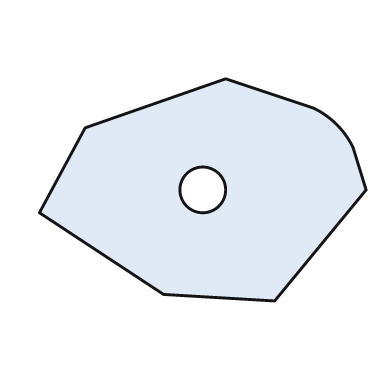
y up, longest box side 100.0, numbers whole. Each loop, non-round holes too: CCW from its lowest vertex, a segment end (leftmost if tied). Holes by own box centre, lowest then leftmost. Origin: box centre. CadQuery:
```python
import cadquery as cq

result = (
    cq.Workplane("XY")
    .moveTo(22.0, -34.0)
    .lineTo(50.0, 0.0)
    .lineTo(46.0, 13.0)
    .threePointArc((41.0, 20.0), (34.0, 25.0))
    .lineTo(7.0, 34.0)
    .lineTo(-36.0, 19.0)
    .lineTo(-50.0, -7.0)
    .lineTo(-12.0, -32.0)
    .close()
    .moveTo(0.0, 0.0)
    .circle(7.0)
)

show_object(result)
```